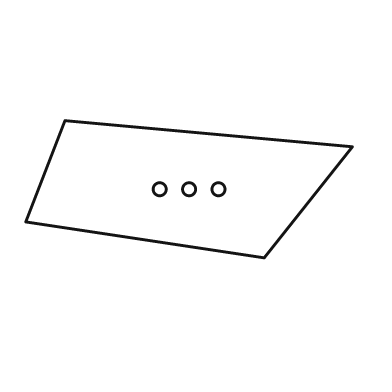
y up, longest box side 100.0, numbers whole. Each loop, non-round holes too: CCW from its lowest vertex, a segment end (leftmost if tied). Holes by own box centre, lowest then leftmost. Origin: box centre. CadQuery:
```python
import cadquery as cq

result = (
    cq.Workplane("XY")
    .moveTo(23.0, -21.0)
    .lineTo(50.0, 13.0)
    .lineTo(-38.0, 21.0)
    .lineTo(-50.0, -10.0)
    .close()
    .moveTo(-9.0, 0.0)
    .circle(2.0)
    .moveTo(0.0, 0.0)
    .circle(2.0)
    .moveTo(9.0, 0.0)
    .circle(2.0)
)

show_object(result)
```